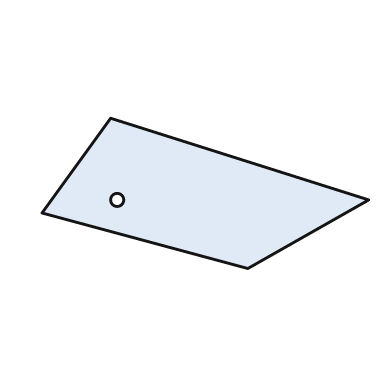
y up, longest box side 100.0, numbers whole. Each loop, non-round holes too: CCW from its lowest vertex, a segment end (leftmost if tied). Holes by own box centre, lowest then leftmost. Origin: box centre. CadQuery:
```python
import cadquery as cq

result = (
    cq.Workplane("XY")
    .moveTo(13.0, -23.0)
    .lineTo(50.0, -2.0)
    .lineTo(-29.0, 23.0)
    .lineTo(-50.0, -6.0)
    .close()
    .moveTo(-27.0, -2.0)
    .circle(2.0)
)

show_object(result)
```